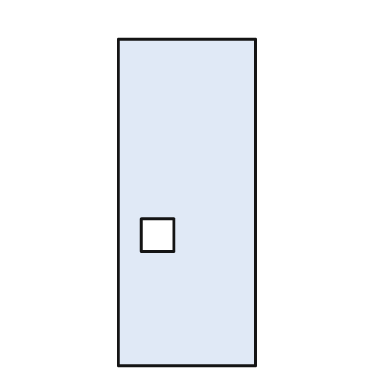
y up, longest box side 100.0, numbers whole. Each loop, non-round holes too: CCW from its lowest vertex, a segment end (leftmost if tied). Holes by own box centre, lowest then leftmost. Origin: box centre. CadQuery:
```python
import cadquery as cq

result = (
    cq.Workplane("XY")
    .moveTo(-21.0, -50.0)
    .lineTo(21.0, -50.0)
    .lineTo(21.0, 50.0)
    .lineTo(-21.0, 50.0)
    .close()
    .moveTo(-14.0, -15.0)
    .lineTo(-4.0, -15.0)
    .lineTo(-4.0, -5.0)
    .lineTo(-14.0, -5.0)
    .close()
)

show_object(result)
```